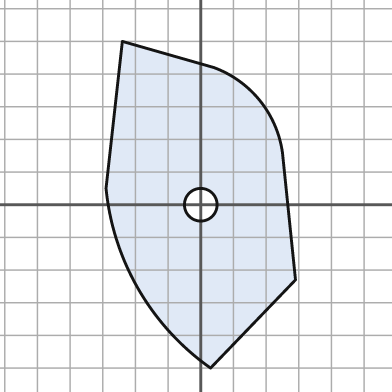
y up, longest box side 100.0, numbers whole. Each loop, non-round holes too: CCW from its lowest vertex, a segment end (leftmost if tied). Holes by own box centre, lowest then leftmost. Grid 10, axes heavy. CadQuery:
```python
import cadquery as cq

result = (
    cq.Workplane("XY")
    .moveTo(3.0, -50.0)
    .lineTo(29.0, -23.0)
    .lineTo(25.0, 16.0)
    .threePointArc((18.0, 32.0), (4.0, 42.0))
    .lineTo(-24.0, 50.0)
    .lineTo(-29.0, 5.0)
    .threePointArc((-19.0, -26.0), (3.0, -50.0))
    .close()
    .moveTo(0.0, 0.0)
    .circle(5.0)
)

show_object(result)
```